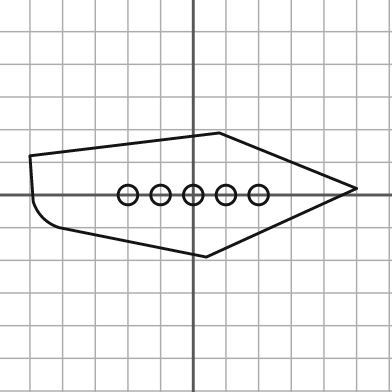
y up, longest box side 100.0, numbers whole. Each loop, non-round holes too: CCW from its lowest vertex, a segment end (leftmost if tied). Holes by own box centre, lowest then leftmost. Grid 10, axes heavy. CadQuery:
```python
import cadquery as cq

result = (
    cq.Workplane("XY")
    .moveTo(4.0, -19.0)
    .lineTo(50.0, 2.0)
    .lineTo(8.0, 19.0)
    .lineTo(-50.0, 12.0)
    .lineTo(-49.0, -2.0)
    .threePointArc((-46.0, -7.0), (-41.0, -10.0))
    .close()
    .moveTo(-20.0, 0.0)
    .circle(3.0)
    .moveTo(-10.0, 0.0)
    .circle(3.0)
    .moveTo(0.0, 0.0)
    .circle(3.0)
    .moveTo(10.0, 0.0)
    .circle(3.0)
    .moveTo(20.0, 0.0)
    .circle(3.0)
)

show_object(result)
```